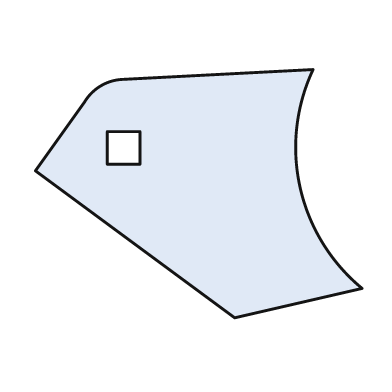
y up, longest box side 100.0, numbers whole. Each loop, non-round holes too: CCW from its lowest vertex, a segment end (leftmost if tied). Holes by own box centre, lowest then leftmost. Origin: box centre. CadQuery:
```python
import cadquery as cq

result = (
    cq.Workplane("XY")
    .moveTo(11.0, -38.0)
    .lineTo(50.0, -29.0)
    .threePointArc((31.0, 2.0), (35.0, 38.0))
    .lineTo(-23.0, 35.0)
    .threePointArc((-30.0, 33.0), (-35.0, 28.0))
    .lineTo(-50.0, 7.0)
    .close()
    .moveTo(-28.0, 9.0)
    .lineTo(-18.0, 9.0)
    .lineTo(-18.0, 19.0)
    .lineTo(-28.0, 19.0)
    .close()
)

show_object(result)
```